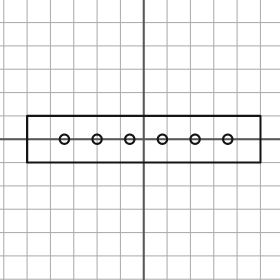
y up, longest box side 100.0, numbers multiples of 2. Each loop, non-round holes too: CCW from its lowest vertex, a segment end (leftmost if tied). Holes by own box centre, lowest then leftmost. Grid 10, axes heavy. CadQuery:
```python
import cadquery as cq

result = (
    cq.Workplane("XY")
    .moveTo(-50.0, -10.0)
    .lineTo(50.0, -10.0)
    .lineTo(50.0, 10.0)
    .lineTo(-50.0, 10.0)
    .close()
    .moveTo(-34.0, 0.0)
    .circle(2.0)
    .moveTo(-20.0, 0.0)
    .circle(2.0)
    .moveTo(-6.0, 0.0)
    .circle(2.0)
    .moveTo(8.0, 0.0)
    .circle(2.0)
    .moveTo(22.0, 0.0)
    .circle(2.0)
    .moveTo(36.0, 0.0)
    .circle(2.0)
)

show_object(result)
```